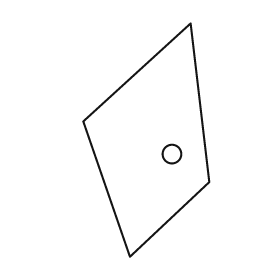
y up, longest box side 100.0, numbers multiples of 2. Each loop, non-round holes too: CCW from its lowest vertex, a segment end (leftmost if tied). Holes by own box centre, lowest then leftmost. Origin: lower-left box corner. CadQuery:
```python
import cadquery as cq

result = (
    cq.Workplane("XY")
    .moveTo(20.0, 0.0)
    .lineTo(54.0, 32.0)
    .lineTo(46.0, 100.0)
    .lineTo(0.0, 58.0)
    .close()
    .moveTo(38.0, 44.0)
    .circle(4.0)
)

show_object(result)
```